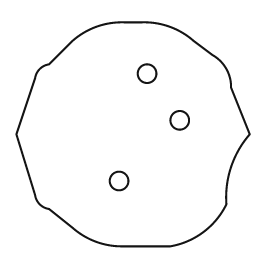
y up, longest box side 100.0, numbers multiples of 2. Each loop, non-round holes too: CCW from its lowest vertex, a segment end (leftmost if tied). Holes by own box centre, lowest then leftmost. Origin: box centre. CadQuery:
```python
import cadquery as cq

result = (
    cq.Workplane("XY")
    .moveTo(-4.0, -48.0)
    .lineTo(16.0, -48.0)
    .threePointArc((30.0, -42.0), (40.0, -30.0))
    .threePointArc((42.0, -14.0), (50.0, 0.0))
    .lineTo(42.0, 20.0)
    .threePointArc((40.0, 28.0), (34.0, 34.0))
    .lineTo(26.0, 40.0)
    .threePointArc((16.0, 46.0), (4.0, 48.0))
    .lineTo(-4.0, 48.0)
    .threePointArc((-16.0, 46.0), (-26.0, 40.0))
    .lineTo(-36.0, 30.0)
    .threePointArc((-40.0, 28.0), (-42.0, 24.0))
    .lineTo(-50.0, 0.0)
    .lineTo(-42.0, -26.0)
    .threePointArc((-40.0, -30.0), (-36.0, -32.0))
    .lineTo(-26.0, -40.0)
    .threePointArc((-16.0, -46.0), (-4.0, -48.0))
    .close()
    .moveTo(-6.0, -20.0)
    .circle(4.0)
    .moveTo(20.0, 6.0)
    .circle(4.0)
    .moveTo(6.0, 26.0)
    .circle(4.0)
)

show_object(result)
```